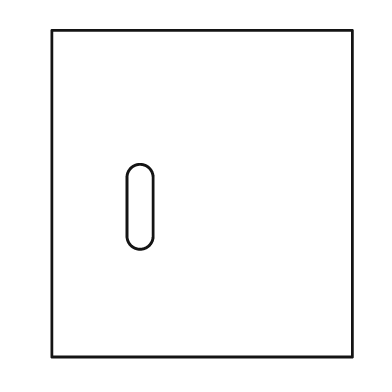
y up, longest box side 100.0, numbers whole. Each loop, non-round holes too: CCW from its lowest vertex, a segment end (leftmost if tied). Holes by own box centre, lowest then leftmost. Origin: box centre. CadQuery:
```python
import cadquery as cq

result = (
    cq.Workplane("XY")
    .moveTo(-46.0, -50.0)
    .lineTo(46.0, -50.0)
    .lineTo(46.0, 50.0)
    .lineTo(-46.0, 50.0)
    .close()
    .moveTo(-23.0, -13.0)
    .threePointArc((-19.0, -17.0), (-15.0, -13.0))
    .lineTo(-15.0, 5.0)
    .threePointArc((-19.0, 9.0), (-23.0, 5.0))
    .close()
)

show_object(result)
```